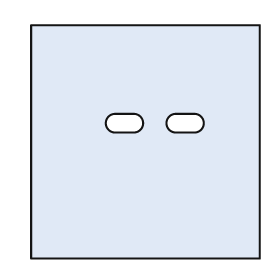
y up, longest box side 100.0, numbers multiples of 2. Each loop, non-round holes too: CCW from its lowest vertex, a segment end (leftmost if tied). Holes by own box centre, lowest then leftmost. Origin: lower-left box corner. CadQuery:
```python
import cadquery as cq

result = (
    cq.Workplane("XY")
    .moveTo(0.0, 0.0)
    .lineTo(98.0, 0.0)
    .lineTo(98.0, 100.0)
    .lineTo(0.0, 100.0)
    .close()
    .moveTo(36.0, 54.0)
    .lineTo(44.0, 54.0)
    .threePointArc((48.0, 58.0), (44.0, 62.0))
    .lineTo(36.0, 62.0)
    .threePointArc((32.0, 58.0), (36.0, 54.0))
    .close()
    .moveTo(62.0, 54.0)
    .lineTo(70.0, 54.0)
    .threePointArc((74.0, 58.0), (70.0, 62.0))
    .lineTo(62.0, 62.0)
    .threePointArc((58.0, 58.0), (62.0, 54.0))
    .close()
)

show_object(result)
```